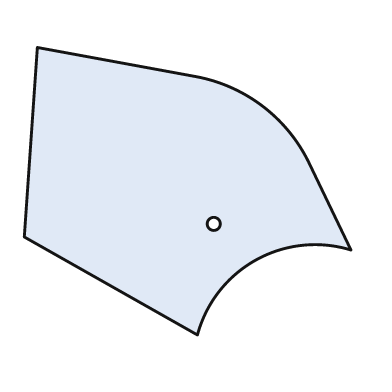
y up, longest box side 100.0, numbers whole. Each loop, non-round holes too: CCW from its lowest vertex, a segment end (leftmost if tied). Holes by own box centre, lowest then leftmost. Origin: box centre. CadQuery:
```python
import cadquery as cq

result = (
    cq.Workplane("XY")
    .moveTo(3.0, -44.0)
    .threePointArc((21.0, -21.0), (50.0, -18.0))
    .lineTo(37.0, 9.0)
    .threePointArc((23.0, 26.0), (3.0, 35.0))
    .lineTo(-46.0, 44.0)
    .lineTo(-50.0, -14.0)
    .close()
    .moveTo(8.0, -10.0)
    .circle(2.0)
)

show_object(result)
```